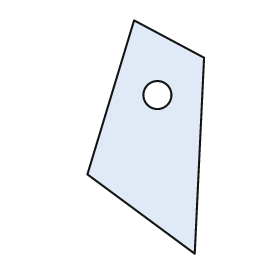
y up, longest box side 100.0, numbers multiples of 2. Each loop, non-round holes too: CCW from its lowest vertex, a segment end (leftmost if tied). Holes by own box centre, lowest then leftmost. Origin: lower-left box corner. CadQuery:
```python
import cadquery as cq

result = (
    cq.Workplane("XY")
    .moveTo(46.0, 0.0)
    .lineTo(50.0, 84.0)
    .lineTo(20.0, 100.0)
    .lineTo(0.0, 34.0)
    .close()
    .moveTo(30.0, 68.0)
    .circle(6.0)
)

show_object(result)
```